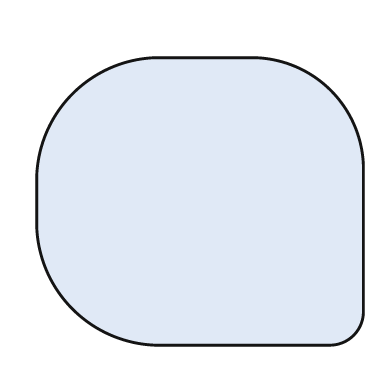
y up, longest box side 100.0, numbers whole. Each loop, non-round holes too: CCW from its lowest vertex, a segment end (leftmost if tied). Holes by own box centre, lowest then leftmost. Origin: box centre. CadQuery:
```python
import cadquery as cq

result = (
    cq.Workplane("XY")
    .moveTo(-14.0, -44.0)
    .lineTo(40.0, -44.0)
    .threePointArc((47.0, -41.0), (50.0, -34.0))
    .lineTo(50.0, 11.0)
    .threePointArc((40.0, 34.0), (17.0, 44.0))
    .lineTo(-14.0, 44.0)
    .threePointArc((-39.0, 33.0), (-50.0, 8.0))
    .lineTo(-50.0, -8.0)
    .threePointArc((-39.0, -33.0), (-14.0, -44.0))
    .close()
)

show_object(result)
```